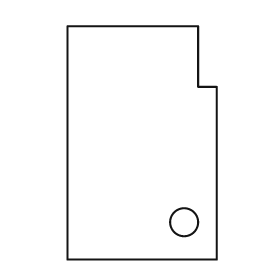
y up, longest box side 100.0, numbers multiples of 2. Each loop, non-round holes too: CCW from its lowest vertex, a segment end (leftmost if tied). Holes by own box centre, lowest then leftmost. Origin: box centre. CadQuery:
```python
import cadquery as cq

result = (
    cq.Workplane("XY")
    .moveTo(-32.0, -50.0)
    .lineTo(32.0, -50.0)
    .lineTo(32.0, 24.0)
    .lineTo(24.0, 24.0)
    .lineTo(24.0, 50.0)
    .lineTo(-32.0, 50.0)
    .close()
    .moveTo(18.0, -34.0)
    .circle(6.0)
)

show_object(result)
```